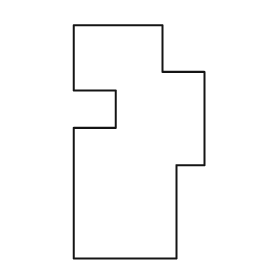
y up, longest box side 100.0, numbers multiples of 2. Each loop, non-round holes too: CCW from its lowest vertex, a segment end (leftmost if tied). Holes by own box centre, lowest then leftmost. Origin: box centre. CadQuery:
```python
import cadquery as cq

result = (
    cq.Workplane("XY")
    .moveTo(-28.0, -50.0)
    .lineTo(16.0, -50.0)
    .lineTo(16.0, -10.0)
    .lineTo(28.0, -10.0)
    .lineTo(28.0, 30.0)
    .lineTo(10.0, 30.0)
    .lineTo(10.0, 50.0)
    .lineTo(-28.0, 50.0)
    .lineTo(-28.0, 22.0)
    .lineTo(-10.0, 22.0)
    .lineTo(-10.0, 6.0)
    .lineTo(-28.0, 6.0)
    .close()
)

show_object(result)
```